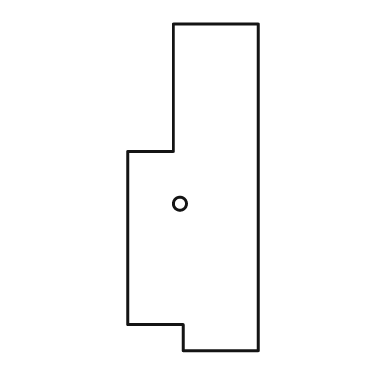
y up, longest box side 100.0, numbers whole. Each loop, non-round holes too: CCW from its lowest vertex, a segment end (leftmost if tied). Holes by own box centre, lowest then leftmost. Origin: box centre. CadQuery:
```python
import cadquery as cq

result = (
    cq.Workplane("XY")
    .moveTo(-3.0, -50.0)
    .lineTo(20.0, -50.0)
    .lineTo(20.0, 50.0)
    .lineTo(-6.0, 50.0)
    .lineTo(-6.0, 11.0)
    .lineTo(-20.0, 11.0)
    .lineTo(-20.0, -42.0)
    .lineTo(-3.0, -42.0)
    .close()
    .moveTo(-4.0, -5.0)
    .circle(2.0)
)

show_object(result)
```